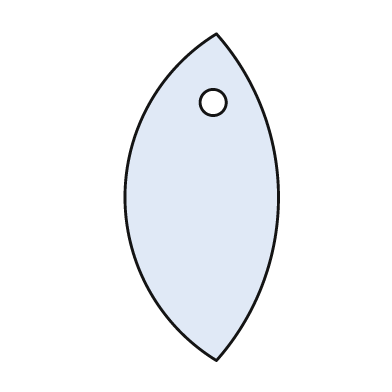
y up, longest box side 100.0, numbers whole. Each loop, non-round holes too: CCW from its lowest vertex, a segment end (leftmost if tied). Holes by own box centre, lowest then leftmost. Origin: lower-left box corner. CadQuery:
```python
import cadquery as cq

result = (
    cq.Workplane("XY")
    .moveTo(28.0, 0.0)
    .threePointArc((47.0, 50.0), (28.0, 100.0))
    .threePointArc((0.0, 50.0), (28.0, 0.0))
    .close()
    .moveTo(27.0, 79.0)
    .circle(4.0)
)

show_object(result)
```